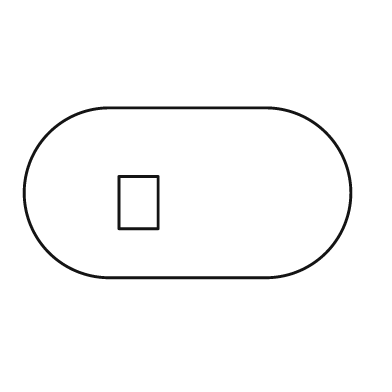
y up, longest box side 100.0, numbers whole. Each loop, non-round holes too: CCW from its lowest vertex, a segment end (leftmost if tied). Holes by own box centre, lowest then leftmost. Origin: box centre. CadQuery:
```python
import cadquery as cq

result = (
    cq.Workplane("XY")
    .moveTo(-24.0, -26.0)
    .lineTo(24.0, -26.0)
    .threePointArc((50.0, 0.0), (24.0, 26.0))
    .lineTo(-24.0, 26.0)
    .threePointArc((-50.0, 0.0), (-24.0, -26.0))
    .close()
    .moveTo(-21.0, -11.0)
    .lineTo(-9.0, -11.0)
    .lineTo(-9.0, 5.0)
    .lineTo(-21.0, 5.0)
    .close()
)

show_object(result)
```